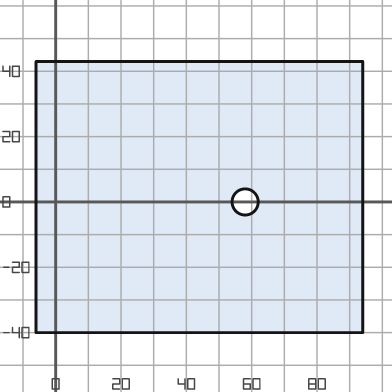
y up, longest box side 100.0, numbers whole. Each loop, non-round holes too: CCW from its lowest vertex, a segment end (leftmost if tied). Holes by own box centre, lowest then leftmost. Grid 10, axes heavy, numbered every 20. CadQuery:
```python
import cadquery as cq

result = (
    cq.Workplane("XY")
    .moveTo(-6.0, -40.0)
    .lineTo(94.0, -40.0)
    .lineTo(94.0, 43.0)
    .lineTo(-6.0, 43.0)
    .close()
    .moveTo(58.0, 0.0)
    .circle(4.0)
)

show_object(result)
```